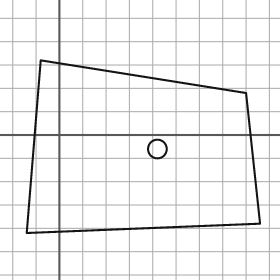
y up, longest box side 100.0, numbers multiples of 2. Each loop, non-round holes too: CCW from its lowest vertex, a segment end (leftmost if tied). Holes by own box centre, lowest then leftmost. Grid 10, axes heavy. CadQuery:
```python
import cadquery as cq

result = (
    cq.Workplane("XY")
    .moveTo(-14.0, -42.0)
    .lineTo(86.0, -38.0)
    .lineTo(80.0, 18.0)
    .lineTo(-8.0, 32.0)
    .close()
    .moveTo(42.0, -6.0)
    .circle(4.0)
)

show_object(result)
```